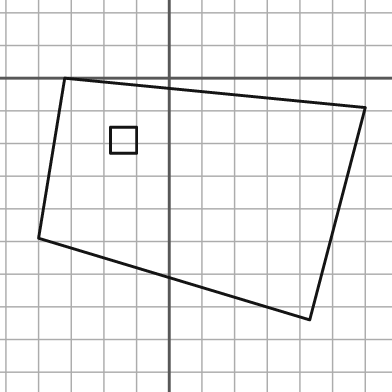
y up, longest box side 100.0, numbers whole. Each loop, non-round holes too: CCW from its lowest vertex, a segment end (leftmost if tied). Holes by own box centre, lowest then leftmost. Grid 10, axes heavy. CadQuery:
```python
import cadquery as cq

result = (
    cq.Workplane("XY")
    .moveTo(43.0, -74.0)
    .lineTo(60.0, -9.0)
    .lineTo(-32.0, 0.0)
    .lineTo(-40.0, -49.0)
    .close()
    .moveTo(-18.0, -23.0)
    .lineTo(-10.0, -23.0)
    .lineTo(-10.0, -15.0)
    .lineTo(-18.0, -15.0)
    .close()
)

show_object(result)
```